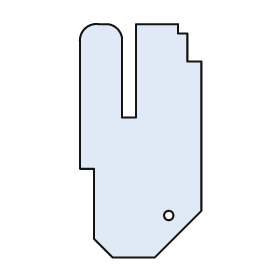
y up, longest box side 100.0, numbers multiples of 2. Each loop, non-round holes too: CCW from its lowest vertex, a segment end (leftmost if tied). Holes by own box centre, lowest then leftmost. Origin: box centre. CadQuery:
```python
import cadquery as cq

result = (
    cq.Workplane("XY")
    .moveTo(-12.0, -50.0)
    .lineTo(6.0, -50.0)
    .lineTo(26.0, -30.0)
    .lineTo(26.0, 34.0)
    .lineTo(20.0, 34.0)
    .lineTo(20.0, 46.0)
    .lineTo(16.0, 46.0)
    .lineTo(16.0, 50.0)
    .lineTo(-2.0, 50.0)
    .lineTo(-2.0, 10.0)
    .lineTo(-8.0, 10.0)
    .lineTo(-8.0, 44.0)
    .threePointArc((-10.0, 48.0), (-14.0, 50.0))
    .lineTo(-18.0, 50.0)
    .threePointArc((-24.0, 48.0), (-26.0, 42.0))
    .lineTo(-26.0, -12.0)
    .lineTo(-20.0, -12.0)
    .lineTo(-20.0, -42.0)
    .close()
    .moveTo(12.0, -32.0)
    .circle(2.0)
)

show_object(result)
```